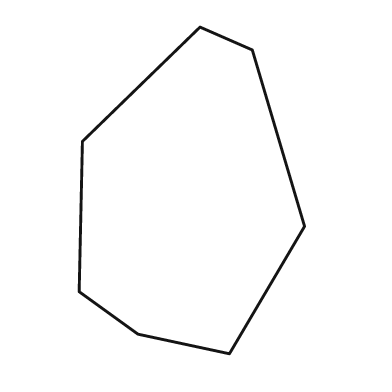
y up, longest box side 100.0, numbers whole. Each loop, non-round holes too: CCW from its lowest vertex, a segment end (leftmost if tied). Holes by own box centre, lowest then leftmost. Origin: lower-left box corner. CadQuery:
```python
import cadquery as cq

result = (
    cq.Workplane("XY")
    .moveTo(46.0, 0.0)
    .lineTo(69.0, 39.0)
    .lineTo(53.0, 93.0)
    .lineTo(37.0, 100.0)
    .lineTo(1.0, 65.0)
    .lineTo(0.0, 19.0)
    .lineTo(18.0, 6.0)
    .close()
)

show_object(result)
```